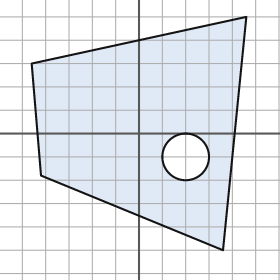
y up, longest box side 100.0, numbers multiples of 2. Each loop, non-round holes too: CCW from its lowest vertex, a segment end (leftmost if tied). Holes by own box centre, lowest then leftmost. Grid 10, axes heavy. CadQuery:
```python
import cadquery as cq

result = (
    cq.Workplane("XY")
    .moveTo(36.0, -50.0)
    .lineTo(46.0, 50.0)
    .lineTo(-46.0, 30.0)
    .lineTo(-42.0, -18.0)
    .close()
    .moveTo(20.0, -10.0)
    .circle(10.0)
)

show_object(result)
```